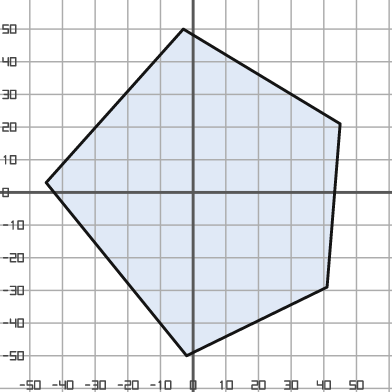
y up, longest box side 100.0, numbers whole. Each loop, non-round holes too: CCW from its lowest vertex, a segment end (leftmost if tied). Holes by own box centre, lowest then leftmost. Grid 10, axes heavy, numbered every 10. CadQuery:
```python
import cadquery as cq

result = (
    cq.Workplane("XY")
    .moveTo(-2.0, -50.0)
    .lineTo(41.0, -29.0)
    .lineTo(45.0, 21.0)
    .lineTo(-3.0, 50.0)
    .lineTo(-45.0, 3.0)
    .close()
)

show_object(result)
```